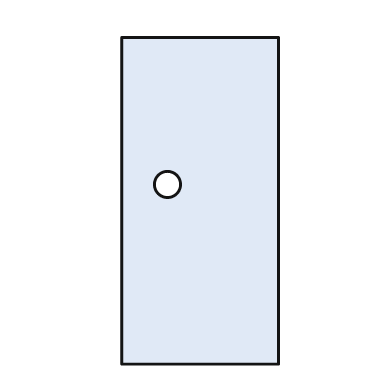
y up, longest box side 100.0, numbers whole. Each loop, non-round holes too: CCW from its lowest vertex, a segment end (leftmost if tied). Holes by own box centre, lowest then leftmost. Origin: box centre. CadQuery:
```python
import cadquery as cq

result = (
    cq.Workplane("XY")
    .moveTo(-24.0, -50.0)
    .lineTo(24.0, -50.0)
    .lineTo(24.0, 50.0)
    .lineTo(-24.0, 50.0)
    .close()
    .moveTo(-10.0, 5.0)
    .circle(4.0)
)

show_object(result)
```